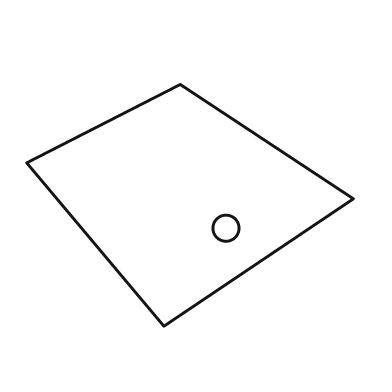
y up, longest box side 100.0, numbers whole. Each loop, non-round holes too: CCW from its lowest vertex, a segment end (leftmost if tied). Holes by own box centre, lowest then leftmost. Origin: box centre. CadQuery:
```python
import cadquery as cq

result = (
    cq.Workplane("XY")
    .moveTo(-8.0, -37.0)
    .lineTo(50.0, 2.0)
    .lineTo(-3.0, 37.0)
    .lineTo(-50.0, 13.0)
    .close()
    .moveTo(11.0, -7.0)
    .circle(4.0)
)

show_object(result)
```